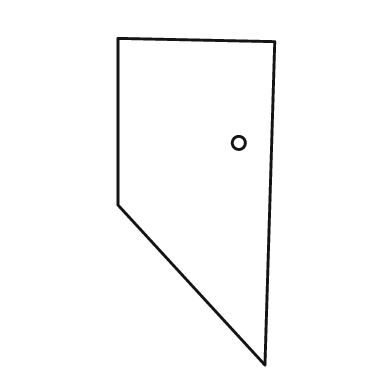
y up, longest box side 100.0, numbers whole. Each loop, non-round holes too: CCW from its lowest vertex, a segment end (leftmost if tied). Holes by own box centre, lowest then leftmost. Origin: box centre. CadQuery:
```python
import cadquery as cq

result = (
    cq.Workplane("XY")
    .moveTo(21.0, -50.0)
    .lineTo(24.0, 49.0)
    .lineTo(-24.0, 50.0)
    .lineTo(-24.0, -1.0)
    .close()
    .moveTo(13.0, 18.0)
    .circle(2.0)
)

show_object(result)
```